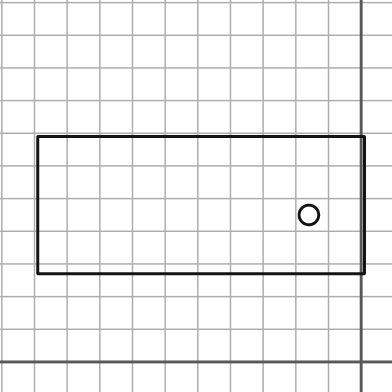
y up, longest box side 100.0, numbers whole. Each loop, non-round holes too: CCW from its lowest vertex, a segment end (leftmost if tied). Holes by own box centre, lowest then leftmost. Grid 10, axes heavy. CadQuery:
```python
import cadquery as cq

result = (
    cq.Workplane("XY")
    .moveTo(-99.0, 27.0)
    .lineTo(1.0, 27.0)
    .lineTo(1.0, 69.0)
    .lineTo(-99.0, 69.0)
    .close()
    .moveTo(-16.0, 45.0)
    .circle(3.0)
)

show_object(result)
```